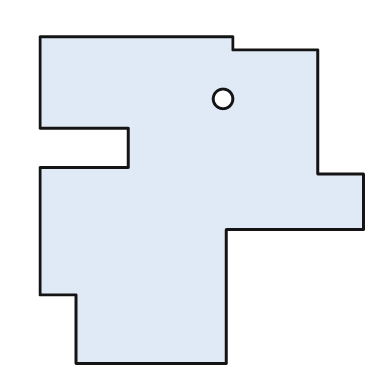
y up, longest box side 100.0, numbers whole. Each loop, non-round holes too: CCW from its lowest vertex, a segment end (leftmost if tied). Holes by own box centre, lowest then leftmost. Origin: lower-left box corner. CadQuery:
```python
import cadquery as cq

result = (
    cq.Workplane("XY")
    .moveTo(11.0, 0.0)
    .lineTo(57.0, 0.0)
    .lineTo(57.0, 41.0)
    .lineTo(99.0, 41.0)
    .lineTo(99.0, 58.0)
    .lineTo(85.0, 58.0)
    .lineTo(85.0, 96.0)
    .lineTo(59.0, 96.0)
    .lineTo(59.0, 100.0)
    .lineTo(0.0, 100.0)
    .lineTo(0.0, 72.0)
    .lineTo(27.0, 72.0)
    .lineTo(27.0, 60.0)
    .lineTo(0.0, 60.0)
    .lineTo(0.0, 21.0)
    .lineTo(11.0, 21.0)
    .close()
    .moveTo(56.0, 81.0)
    .circle(3.0)
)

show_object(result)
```